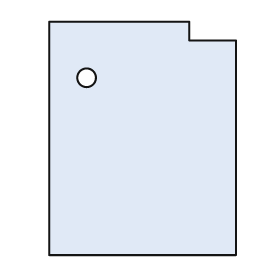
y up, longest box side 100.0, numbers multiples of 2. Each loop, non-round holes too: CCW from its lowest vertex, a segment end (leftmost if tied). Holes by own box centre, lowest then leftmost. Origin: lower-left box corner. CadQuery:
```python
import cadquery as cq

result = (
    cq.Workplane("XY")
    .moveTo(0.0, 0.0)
    .lineTo(80.0, 0.0)
    .lineTo(80.0, 92.0)
    .lineTo(60.0, 92.0)
    .lineTo(60.0, 100.0)
    .lineTo(0.0, 100.0)
    .close()
    .moveTo(16.0, 76.0)
    .circle(4.0)
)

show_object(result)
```